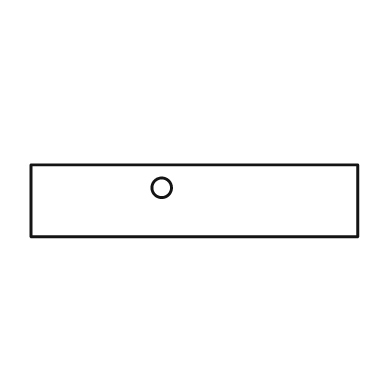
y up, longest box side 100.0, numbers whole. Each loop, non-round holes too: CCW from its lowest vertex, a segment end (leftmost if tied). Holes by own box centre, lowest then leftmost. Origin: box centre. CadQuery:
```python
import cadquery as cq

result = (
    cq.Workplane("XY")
    .moveTo(-50.0, -11.0)
    .lineTo(50.0, -11.0)
    .lineTo(50.0, 11.0)
    .lineTo(-50.0, 11.0)
    .close()
    .moveTo(-10.0, 4.0)
    .circle(3.0)
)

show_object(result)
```